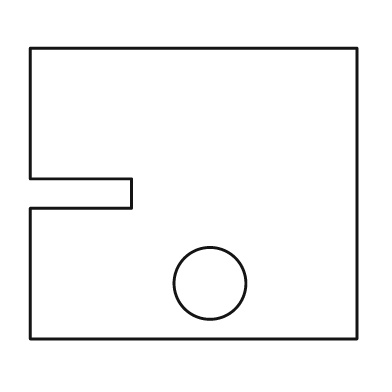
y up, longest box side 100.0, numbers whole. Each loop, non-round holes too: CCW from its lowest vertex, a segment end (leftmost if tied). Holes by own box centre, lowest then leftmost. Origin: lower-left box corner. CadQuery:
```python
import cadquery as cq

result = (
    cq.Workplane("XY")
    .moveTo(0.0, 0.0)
    .lineTo(100.0, 0.0)
    .lineTo(100.0, 89.0)
    .lineTo(0.0, 89.0)
    .lineTo(0.0, 49.0)
    .lineTo(31.0, 49.0)
    .lineTo(31.0, 40.0)
    .lineTo(0.0, 40.0)
    .close()
    .moveTo(55.0, 17.0)
    .circle(11.0)
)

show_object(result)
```